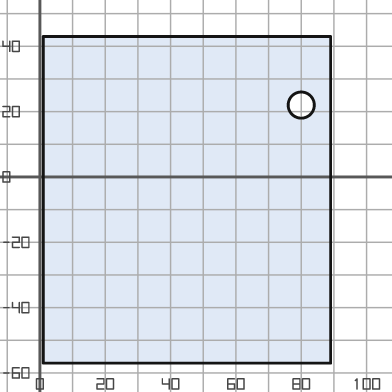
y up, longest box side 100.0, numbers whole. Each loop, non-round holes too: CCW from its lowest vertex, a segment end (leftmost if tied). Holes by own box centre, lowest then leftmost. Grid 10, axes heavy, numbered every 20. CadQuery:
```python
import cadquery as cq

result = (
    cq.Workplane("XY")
    .moveTo(1.0, -57.0)
    .lineTo(89.0, -57.0)
    .lineTo(89.0, 43.0)
    .lineTo(1.0, 43.0)
    .close()
    .moveTo(80.0, 22.0)
    .circle(4.0)
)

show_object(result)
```